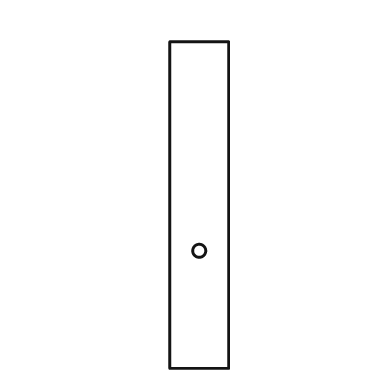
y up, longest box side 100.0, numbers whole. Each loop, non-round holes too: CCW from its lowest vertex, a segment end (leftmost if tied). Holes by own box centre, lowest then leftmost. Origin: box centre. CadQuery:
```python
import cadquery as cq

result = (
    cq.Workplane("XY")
    .moveTo(-9.0, -50.0)
    .lineTo(9.0, -50.0)
    .lineTo(9.0, 50.0)
    .lineTo(-9.0, 50.0)
    .close()
    .moveTo(0.0, -14.0)
    .circle(2.0)
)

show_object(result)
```